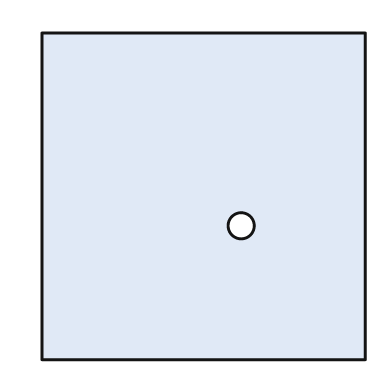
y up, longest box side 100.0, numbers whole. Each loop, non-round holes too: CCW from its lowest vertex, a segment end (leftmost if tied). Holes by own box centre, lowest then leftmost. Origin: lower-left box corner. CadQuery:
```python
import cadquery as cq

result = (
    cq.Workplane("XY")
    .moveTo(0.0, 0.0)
    .lineTo(99.0, 0.0)
    .lineTo(99.0, 100.0)
    .lineTo(0.0, 100.0)
    .close()
    .moveTo(61.0, 41.0)
    .circle(4.0)
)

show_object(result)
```